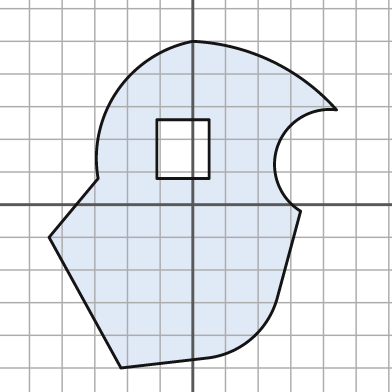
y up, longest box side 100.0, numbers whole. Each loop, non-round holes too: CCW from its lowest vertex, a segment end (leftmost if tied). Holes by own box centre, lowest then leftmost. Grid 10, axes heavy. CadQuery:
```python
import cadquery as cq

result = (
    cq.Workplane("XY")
    .moveTo(-22.0, -50.0)
    .lineTo(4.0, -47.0)
    .threePointArc((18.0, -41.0), (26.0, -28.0))
    .lineTo(33.0, -2.0)
    .threePointArc((26.0, 18.0), (44.0, 29.0))
    .threePointArc((24.0, 44.0), (0.0, 50.0))
    .threePointArc((-23.0, 35.0), (-29.0, 8.0))
    .lineTo(-44.0, -10.0)
    .close()
    .moveTo(-11.0, 8.0)
    .lineTo(5.0, 8.0)
    .lineTo(5.0, 26.0)
    .lineTo(-11.0, 26.0)
    .close()
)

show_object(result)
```